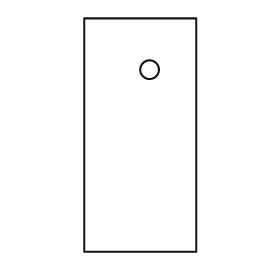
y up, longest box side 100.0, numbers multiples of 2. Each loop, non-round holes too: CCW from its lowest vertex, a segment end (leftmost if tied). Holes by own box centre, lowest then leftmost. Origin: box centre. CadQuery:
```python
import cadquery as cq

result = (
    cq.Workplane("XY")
    .moveTo(-24.0, -50.0)
    .lineTo(24.0, -50.0)
    .lineTo(24.0, 50.0)
    .lineTo(-24.0, 50.0)
    .close()
    .moveTo(4.0, 28.0)
    .circle(4.0)
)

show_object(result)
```